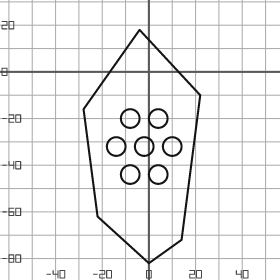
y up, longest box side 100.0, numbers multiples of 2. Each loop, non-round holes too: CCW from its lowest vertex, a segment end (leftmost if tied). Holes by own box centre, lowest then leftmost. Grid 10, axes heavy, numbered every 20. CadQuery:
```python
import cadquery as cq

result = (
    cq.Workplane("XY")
    .moveTo(0.0, -82.0)
    .lineTo(14.0, -72.0)
    .lineTo(22.0, -10.0)
    .lineTo(-4.0, 18.0)
    .lineTo(-28.0, -16.0)
    .lineTo(-22.0, -62.0)
    .close()
    .moveTo(-8.0, -44.0)
    .circle(4.0)
    .moveTo(4.0, -44.0)
    .circle(4.0)
    .moveTo(-14.0, -32.0)
    .circle(4.0)
    .moveTo(-2.0, -32.0)
    .circle(4.0)
    .moveTo(10.0, -32.0)
    .circle(4.0)
    .moveTo(-8.0, -20.0)
    .circle(4.0)
    .moveTo(4.0, -20.0)
    .circle(4.0)
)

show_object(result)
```